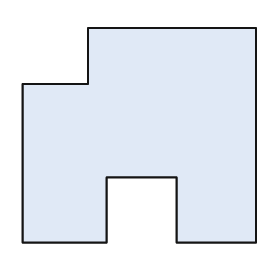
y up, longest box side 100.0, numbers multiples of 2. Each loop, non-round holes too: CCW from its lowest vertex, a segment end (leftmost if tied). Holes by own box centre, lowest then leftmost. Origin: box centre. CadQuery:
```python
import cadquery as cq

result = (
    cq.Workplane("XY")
    .moveTo(-50.0, -46.0)
    .lineTo(-14.0, -46.0)
    .lineTo(-14.0, -18.0)
    .lineTo(16.0, -18.0)
    .lineTo(16.0, -46.0)
    .lineTo(50.0, -46.0)
    .lineTo(50.0, 46.0)
    .lineTo(-22.0, 46.0)
    .lineTo(-22.0, 22.0)
    .lineTo(-50.0, 22.0)
    .close()
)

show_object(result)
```